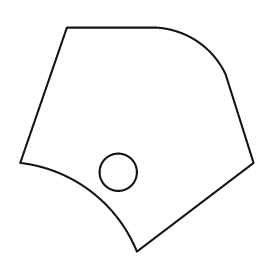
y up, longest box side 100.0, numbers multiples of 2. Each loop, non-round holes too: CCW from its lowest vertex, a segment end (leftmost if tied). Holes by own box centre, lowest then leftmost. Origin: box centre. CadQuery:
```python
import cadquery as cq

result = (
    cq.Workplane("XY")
    .moveTo(0.0, -48.0)
    .lineTo(50.0, -10.0)
    .lineTo(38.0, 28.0)
    .threePointArc((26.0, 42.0), (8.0, 48.0))
    .lineTo(-30.0, 48.0)
    .lineTo(-50.0, -10.0)
    .threePointArc((-20.0, -22.0), (0.0, -48.0))
    .close()
    .moveTo(-8.0, -14.0)
    .circle(8.0)
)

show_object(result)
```